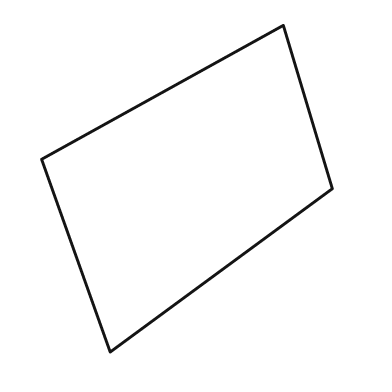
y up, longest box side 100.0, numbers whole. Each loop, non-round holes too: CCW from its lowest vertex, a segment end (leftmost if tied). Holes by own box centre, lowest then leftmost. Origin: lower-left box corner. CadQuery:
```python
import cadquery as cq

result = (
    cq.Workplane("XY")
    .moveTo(21.0, 0.0)
    .lineTo(89.0, 50.0)
    .lineTo(74.0, 100.0)
    .lineTo(0.0, 59.0)
    .close()
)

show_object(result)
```